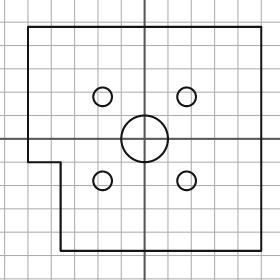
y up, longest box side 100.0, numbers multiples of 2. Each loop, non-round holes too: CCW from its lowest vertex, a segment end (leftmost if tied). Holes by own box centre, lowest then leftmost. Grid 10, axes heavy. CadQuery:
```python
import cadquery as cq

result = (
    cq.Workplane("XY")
    .moveTo(-36.0, -48.0)
    .lineTo(50.0, -48.0)
    .lineTo(50.0, 48.0)
    .lineTo(-50.0, 48.0)
    .lineTo(-50.0, -10.0)
    .lineTo(-36.0, -10.0)
    .close()
    .moveTo(-18.0, -18.0)
    .circle(4.0)
    .moveTo(18.0, -18.0)
    .circle(4.0)
    .moveTo(0.0, 0.0)
    .circle(10.0)
    .moveTo(-18.0, 18.0)
    .circle(4.0)
    .moveTo(18.0, 18.0)
    .circle(4.0)
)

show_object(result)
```